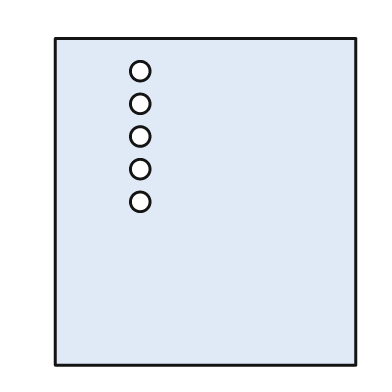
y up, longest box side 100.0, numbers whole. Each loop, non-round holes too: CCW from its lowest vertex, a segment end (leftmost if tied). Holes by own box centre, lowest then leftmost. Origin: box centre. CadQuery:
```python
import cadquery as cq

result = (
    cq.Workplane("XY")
    .moveTo(-46.0, -50.0)
    .lineTo(46.0, -50.0)
    .lineTo(46.0, 50.0)
    .lineTo(-46.0, 50.0)
    .close()
    .moveTo(-20.0, 0.0)
    .circle(3.0)
    .moveTo(-20.0, 10.0)
    .circle(3.0)
    .moveTo(-20.0, 20.0)
    .circle(3.0)
    .moveTo(-20.0, 30.0)
    .circle(3.0)
    .moveTo(-20.0, 40.0)
    .circle(3.0)
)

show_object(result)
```